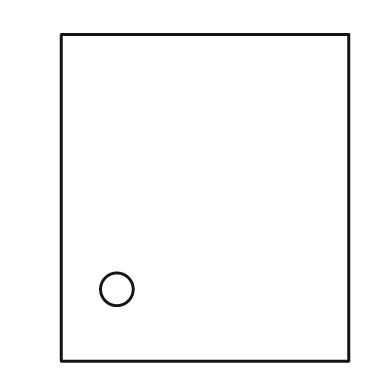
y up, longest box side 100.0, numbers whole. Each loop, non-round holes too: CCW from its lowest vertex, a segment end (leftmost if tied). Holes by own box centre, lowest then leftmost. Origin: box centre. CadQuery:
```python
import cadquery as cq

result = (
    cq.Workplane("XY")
    .moveTo(-44.0, -50.0)
    .lineTo(44.0, -50.0)
    .lineTo(44.0, 50.0)
    .lineTo(-44.0, 50.0)
    .close()
    .moveTo(-27.0, -28.0)
    .circle(5.0)
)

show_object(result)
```